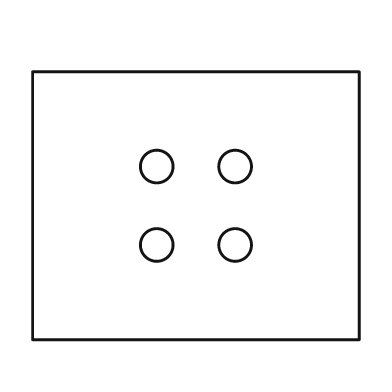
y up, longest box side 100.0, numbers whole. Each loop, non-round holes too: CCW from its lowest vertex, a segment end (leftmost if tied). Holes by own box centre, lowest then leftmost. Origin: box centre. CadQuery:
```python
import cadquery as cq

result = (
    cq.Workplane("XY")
    .moveTo(-50.0, -41.0)
    .lineTo(50.0, -41.0)
    .lineTo(50.0, 41.0)
    .lineTo(-50.0, 41.0)
    .close()
    .moveTo(-12.0, -12.0)
    .circle(5.0)
    .moveTo(12.0, -12.0)
    .circle(5.0)
    .moveTo(-12.0, 12.0)
    .circle(5.0)
    .moveTo(12.0, 12.0)
    .circle(5.0)
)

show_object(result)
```